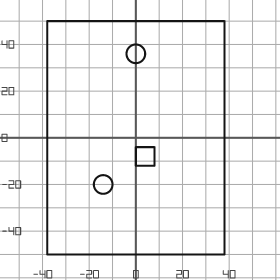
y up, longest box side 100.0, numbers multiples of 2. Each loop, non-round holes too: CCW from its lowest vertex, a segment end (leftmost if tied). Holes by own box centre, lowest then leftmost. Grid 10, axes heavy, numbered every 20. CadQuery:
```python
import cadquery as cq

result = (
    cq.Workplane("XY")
    .moveTo(-38.0, -50.0)
    .lineTo(38.0, -50.0)
    .lineTo(38.0, 50.0)
    .lineTo(-38.0, 50.0)
    .close()
    .moveTo(-14.0, -20.0)
    .circle(4.0)
    .moveTo(0.0, -12.0)
    .lineTo(8.0, -12.0)
    .lineTo(8.0, -4.0)
    .lineTo(0.0, -4.0)
    .close()
    .moveTo(0.0, 36.0)
    .circle(4.0)
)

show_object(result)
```